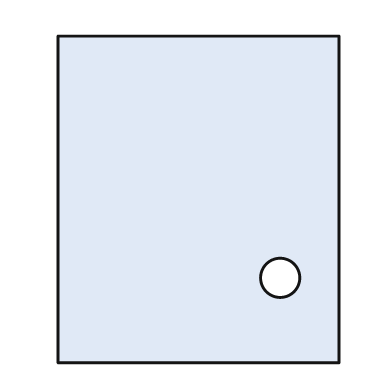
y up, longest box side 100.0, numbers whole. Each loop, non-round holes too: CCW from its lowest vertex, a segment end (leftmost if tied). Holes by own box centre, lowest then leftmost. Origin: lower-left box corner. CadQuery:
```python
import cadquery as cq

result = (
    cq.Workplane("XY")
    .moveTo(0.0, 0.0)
    .lineTo(86.0, 0.0)
    .lineTo(86.0, 100.0)
    .lineTo(0.0, 100.0)
    .close()
    .moveTo(68.0, 26.0)
    .circle(6.0)
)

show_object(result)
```